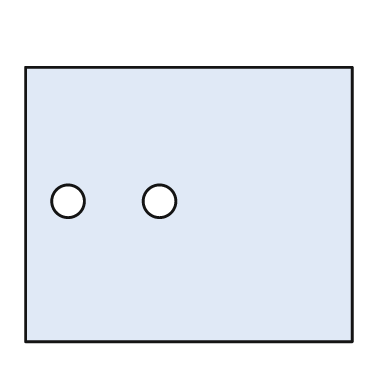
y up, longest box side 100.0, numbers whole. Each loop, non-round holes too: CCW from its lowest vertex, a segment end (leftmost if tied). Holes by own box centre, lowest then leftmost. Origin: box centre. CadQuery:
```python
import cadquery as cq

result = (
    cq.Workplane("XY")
    .moveTo(-50.0, -42.0)
    .lineTo(50.0, -42.0)
    .lineTo(50.0, 42.0)
    .lineTo(-50.0, 42.0)
    .close()
    .moveTo(-37.0, 1.0)
    .circle(5.0)
    .moveTo(-9.0, 1.0)
    .circle(5.0)
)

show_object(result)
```